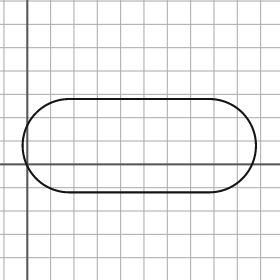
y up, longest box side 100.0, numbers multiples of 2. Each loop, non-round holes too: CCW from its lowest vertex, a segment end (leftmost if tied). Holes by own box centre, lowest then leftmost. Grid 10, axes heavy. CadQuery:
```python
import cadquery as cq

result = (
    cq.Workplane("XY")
    .moveTo(18.0, -12.0)
    .lineTo(78.0, -12.0)
    .threePointArc((98.0, 8.0), (78.0, 28.0))
    .lineTo(18.0, 28.0)
    .threePointArc((-2.0, 8.0), (18.0, -12.0))
    .close()
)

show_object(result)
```